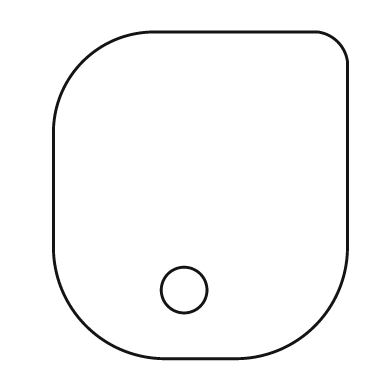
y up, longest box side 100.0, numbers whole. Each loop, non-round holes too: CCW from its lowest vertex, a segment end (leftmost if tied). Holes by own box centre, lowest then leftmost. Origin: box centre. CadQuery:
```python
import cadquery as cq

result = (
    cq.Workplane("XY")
    .moveTo(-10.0, -50.0)
    .lineTo(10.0, -50.0)
    .threePointArc((35.0, -40.0), (45.0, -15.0))
    .lineTo(45.0, 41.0)
    .threePointArc((42.0, 47.0), (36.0, 50.0))
    .lineTo(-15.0, 50.0)
    .threePointArc((-36.0, 41.0), (-45.0, 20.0))
    .lineTo(-45.0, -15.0)
    .threePointArc((-35.0, -40.0), (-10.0, -50.0))
    .close()
    .moveTo(-5.0, -29.0)
    .circle(7.0)
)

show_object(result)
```